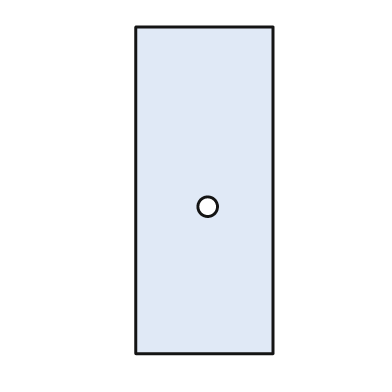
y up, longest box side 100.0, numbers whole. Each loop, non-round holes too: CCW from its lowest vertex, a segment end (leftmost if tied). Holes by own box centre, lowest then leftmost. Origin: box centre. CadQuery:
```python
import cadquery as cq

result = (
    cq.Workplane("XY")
    .moveTo(-21.0, -50.0)
    .lineTo(21.0, -50.0)
    .lineTo(21.0, 50.0)
    .lineTo(-21.0, 50.0)
    .close()
    .moveTo(1.0, -5.0)
    .circle(3.0)
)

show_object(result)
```